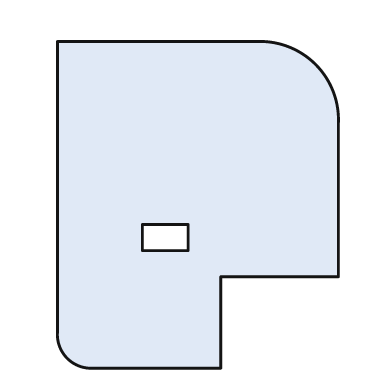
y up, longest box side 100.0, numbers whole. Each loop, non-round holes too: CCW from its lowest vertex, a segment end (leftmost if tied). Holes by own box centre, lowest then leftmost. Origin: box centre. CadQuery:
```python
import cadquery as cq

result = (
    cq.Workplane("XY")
    .moveTo(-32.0, -50.0)
    .lineTo(7.0, -50.0)
    .lineTo(7.0, -22.0)
    .lineTo(43.0, -22.0)
    .lineTo(43.0, 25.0)
    .threePointArc((36.0, 43.0), (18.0, 50.0))
    .lineTo(-43.0, 50.0)
    .lineTo(-43.0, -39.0)
    .threePointArc((-40.0, -47.0), (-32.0, -50.0))
    .close()
    .moveTo(-17.0, -14.0)
    .lineTo(-3.0, -14.0)
    .lineTo(-3.0, -6.0)
    .lineTo(-17.0, -6.0)
    .close()
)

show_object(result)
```